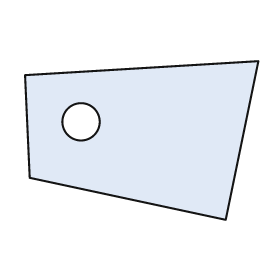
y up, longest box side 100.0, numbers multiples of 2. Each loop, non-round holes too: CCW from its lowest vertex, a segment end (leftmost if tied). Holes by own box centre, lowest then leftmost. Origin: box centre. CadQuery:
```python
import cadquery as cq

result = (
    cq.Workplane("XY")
    .moveTo(36.0, -34.0)
    .lineTo(50.0, 34.0)
    .lineTo(-50.0, 28.0)
    .lineTo(-48.0, -16.0)
    .close()
    .moveTo(-26.0, 8.0)
    .circle(8.0)
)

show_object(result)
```